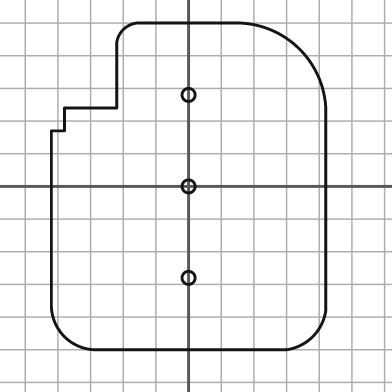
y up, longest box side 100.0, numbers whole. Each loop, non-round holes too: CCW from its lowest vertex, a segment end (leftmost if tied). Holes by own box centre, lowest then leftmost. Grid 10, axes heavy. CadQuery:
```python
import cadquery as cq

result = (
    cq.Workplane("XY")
    .moveTo(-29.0, -50.0)
    .lineTo(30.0, -50.0)
    .threePointArc((38.0, -46.0), (42.0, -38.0))
    .lineTo(42.0, 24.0)
    .threePointArc((34.0, 42.0), (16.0, 50.0))
    .lineTo(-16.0, 50.0)
    .threePointArc((-20.0, 48.0), (-22.0, 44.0))
    .lineTo(-22.0, 24.0)
    .lineTo(-38.0, 24.0)
    .lineTo(-38.0, 17.0)
    .lineTo(-42.0, 17.0)
    .lineTo(-42.0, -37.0)
    .threePointArc((-38.0, -46.0), (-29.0, -50.0))
    .close()
    .moveTo(0.0, -28.0)
    .circle(2.0)
    .moveTo(0.0, 0.0)
    .circle(2.0)
    .moveTo(0.0, 28.0)
    .circle(2.0)
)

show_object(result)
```